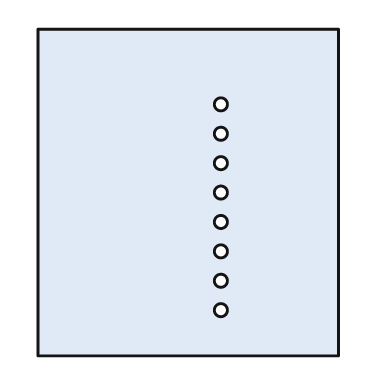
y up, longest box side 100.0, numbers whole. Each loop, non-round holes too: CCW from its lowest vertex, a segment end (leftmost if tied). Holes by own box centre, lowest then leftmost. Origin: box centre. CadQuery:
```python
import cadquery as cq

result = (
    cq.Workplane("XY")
    .moveTo(-46.0, -50.0)
    .lineTo(46.0, -50.0)
    .lineTo(46.0, 50.0)
    .lineTo(-46.0, 50.0)
    .close()
    .moveTo(10.0, -36.0)
    .circle(2.0)
    .moveTo(10.0, -27.0)
    .circle(2.0)
    .moveTo(10.0, -18.0)
    .circle(2.0)
    .moveTo(10.0, -9.0)
    .circle(2.0)
    .moveTo(10.0, 0.0)
    .circle(2.0)
    .moveTo(10.0, 9.0)
    .circle(2.0)
    .moveTo(10.0, 18.0)
    .circle(2.0)
    .moveTo(10.0, 27.0)
    .circle(2.0)
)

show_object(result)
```